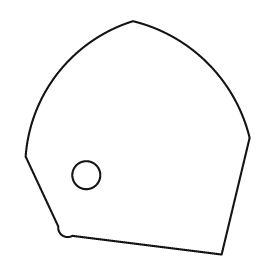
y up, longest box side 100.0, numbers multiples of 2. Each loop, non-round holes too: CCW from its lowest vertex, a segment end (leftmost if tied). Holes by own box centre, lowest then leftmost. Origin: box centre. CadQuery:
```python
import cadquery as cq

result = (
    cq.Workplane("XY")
    .moveTo(36.0, -50.0)
    .lineTo(48.0, 0.0)
    .threePointArc((30.0, 32.0), (-2.0, 50.0))
    .threePointArc((-34.0, 28.0), (-48.0, -8.0))
    .lineTo(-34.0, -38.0)
    .threePointArc((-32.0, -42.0), (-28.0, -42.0))
    .close()
    .moveTo(-22.0, -16.0)
    .circle(6.0)
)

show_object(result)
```